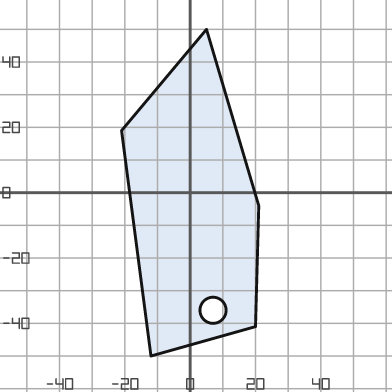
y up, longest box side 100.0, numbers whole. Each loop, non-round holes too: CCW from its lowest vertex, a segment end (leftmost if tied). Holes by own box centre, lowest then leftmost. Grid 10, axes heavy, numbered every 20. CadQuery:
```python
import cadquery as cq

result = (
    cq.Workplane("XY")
    .moveTo(-12.0, -50.0)
    .lineTo(20.0, -41.0)
    .lineTo(21.0, -4.0)
    .lineTo(5.0, 50.0)
    .lineTo(-21.0, 19.0)
    .close()
    .moveTo(7.0, -36.0)
    .circle(4.0)
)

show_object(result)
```